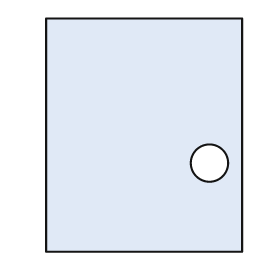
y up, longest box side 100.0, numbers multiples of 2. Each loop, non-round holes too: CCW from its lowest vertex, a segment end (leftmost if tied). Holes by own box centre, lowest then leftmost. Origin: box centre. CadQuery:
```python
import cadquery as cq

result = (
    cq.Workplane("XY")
    .moveTo(-42.0, -50.0)
    .lineTo(42.0, -50.0)
    .lineTo(42.0, 50.0)
    .lineTo(-42.0, 50.0)
    .close()
    .moveTo(28.0, -12.0)
    .circle(8.0)
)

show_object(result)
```